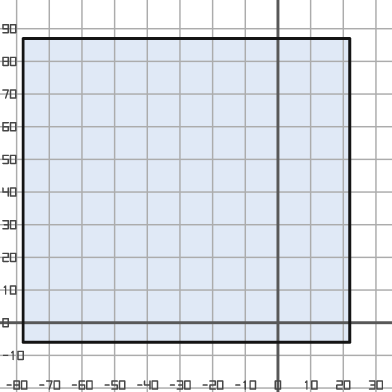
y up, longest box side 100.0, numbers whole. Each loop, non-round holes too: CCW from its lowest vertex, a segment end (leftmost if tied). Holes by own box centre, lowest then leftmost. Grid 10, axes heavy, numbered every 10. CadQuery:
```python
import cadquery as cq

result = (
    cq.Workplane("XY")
    .moveTo(-78.0, -6.0)
    .lineTo(22.0, -6.0)
    .lineTo(22.0, 87.0)
    .lineTo(-78.0, 87.0)
    .close()
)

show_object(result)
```